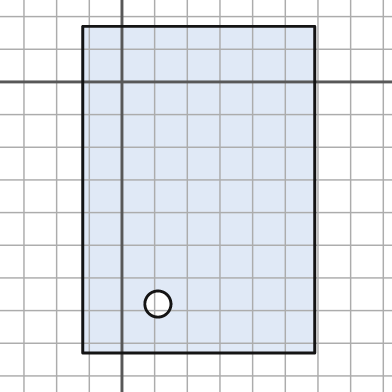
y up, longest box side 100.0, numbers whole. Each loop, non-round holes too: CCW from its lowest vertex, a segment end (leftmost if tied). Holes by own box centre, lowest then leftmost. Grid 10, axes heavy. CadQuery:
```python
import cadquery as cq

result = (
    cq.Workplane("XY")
    .moveTo(-12.0, -83.0)
    .lineTo(59.0, -83.0)
    .lineTo(59.0, 17.0)
    .lineTo(-12.0, 17.0)
    .close()
    .moveTo(11.0, -68.0)
    .circle(4.0)
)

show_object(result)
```